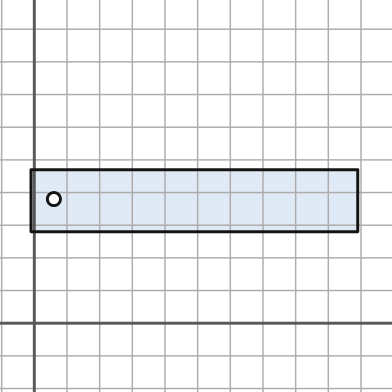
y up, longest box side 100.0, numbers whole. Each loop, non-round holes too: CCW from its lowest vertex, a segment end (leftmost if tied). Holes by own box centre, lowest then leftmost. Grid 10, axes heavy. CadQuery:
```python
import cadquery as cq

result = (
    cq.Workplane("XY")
    .moveTo(-1.0, 28.0)
    .lineTo(99.0, 28.0)
    .lineTo(99.0, 47.0)
    .lineTo(-1.0, 47.0)
    .close()
    .moveTo(6.0, 38.0)
    .circle(2.0)
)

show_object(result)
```